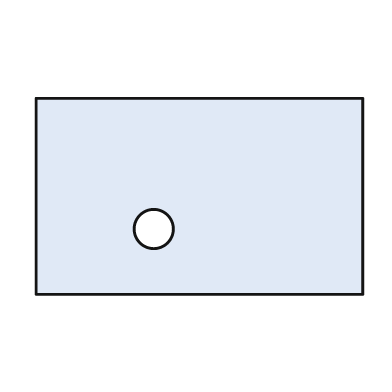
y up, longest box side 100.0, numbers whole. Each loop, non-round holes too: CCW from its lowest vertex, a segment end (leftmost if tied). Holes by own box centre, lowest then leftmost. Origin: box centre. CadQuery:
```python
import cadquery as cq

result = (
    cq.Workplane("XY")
    .moveTo(-50.0, -30.0)
    .lineTo(50.0, -30.0)
    .lineTo(50.0, 30.0)
    .lineTo(-50.0, 30.0)
    .close()
    .moveTo(-14.0, -10.0)
    .circle(6.0)
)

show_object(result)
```